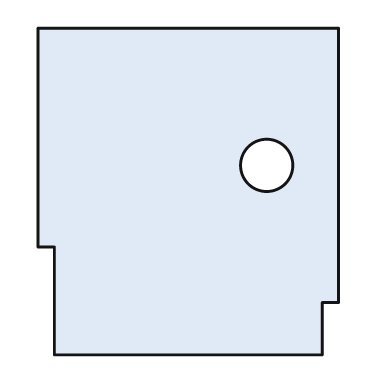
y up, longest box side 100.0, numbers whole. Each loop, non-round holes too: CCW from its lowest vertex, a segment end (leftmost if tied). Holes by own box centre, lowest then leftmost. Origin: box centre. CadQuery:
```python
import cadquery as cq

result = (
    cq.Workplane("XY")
    .moveTo(-41.0, -50.0)
    .lineTo(41.0, -50.0)
    .lineTo(41.0, -34.0)
    .lineTo(46.0, -34.0)
    .lineTo(46.0, 50.0)
    .lineTo(-46.0, 50.0)
    .lineTo(-46.0, -17.0)
    .lineTo(-41.0, -17.0)
    .close()
    .moveTo(24.0, 8.0)
    .circle(8.0)
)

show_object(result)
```